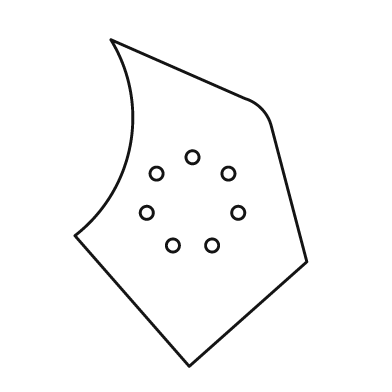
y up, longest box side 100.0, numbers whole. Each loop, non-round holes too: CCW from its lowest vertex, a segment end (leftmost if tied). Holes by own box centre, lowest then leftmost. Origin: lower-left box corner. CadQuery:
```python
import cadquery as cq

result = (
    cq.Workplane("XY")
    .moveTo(35.0, 0.0)
    .lineTo(71.0, 32.0)
    .lineTo(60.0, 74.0)
    .threePointArc((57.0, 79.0), (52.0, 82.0))
    .lineTo(11.0, 100.0)
    .threePointArc((17.0, 68.0), (0.0, 40.0))
    .close()
    .moveTo(30.0, 37.0)
    .circle(2.0)
    .moveTo(42.0, 37.0)
    .circle(2.0)
    .moveTo(22.0, 47.0)
    .circle(2.0)
    .moveTo(50.0, 47.0)
    .circle(2.0)
    .moveTo(25.0, 59.0)
    .circle(2.0)
    .moveTo(47.0, 59.0)
    .circle(2.0)
    .moveTo(36.0, 64.0)
    .circle(2.0)
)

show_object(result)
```